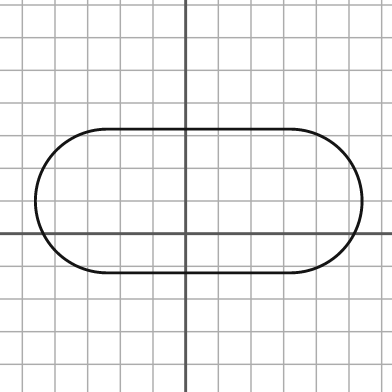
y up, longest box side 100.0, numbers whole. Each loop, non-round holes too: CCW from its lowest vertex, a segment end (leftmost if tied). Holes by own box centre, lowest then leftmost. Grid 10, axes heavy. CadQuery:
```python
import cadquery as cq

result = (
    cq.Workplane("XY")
    .moveTo(-24.0, -12.0)
    .lineTo(32.0, -12.0)
    .threePointArc((54.0, 10.0), (32.0, 32.0))
    .lineTo(-24.0, 32.0)
    .threePointArc((-46.0, 10.0), (-24.0, -12.0))
    .close()
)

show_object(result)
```